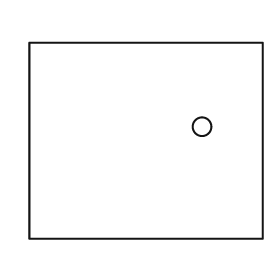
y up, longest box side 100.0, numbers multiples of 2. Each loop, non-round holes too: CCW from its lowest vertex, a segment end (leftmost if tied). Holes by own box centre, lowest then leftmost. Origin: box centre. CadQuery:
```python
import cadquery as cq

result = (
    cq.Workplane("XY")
    .moveTo(-50.0, -42.0)
    .lineTo(50.0, -42.0)
    .lineTo(50.0, 42.0)
    .lineTo(-50.0, 42.0)
    .close()
    .moveTo(24.0, 6.0)
    .circle(4.0)
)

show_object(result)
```